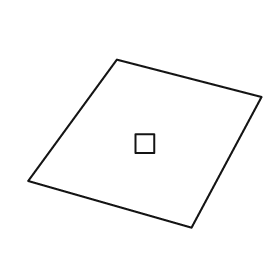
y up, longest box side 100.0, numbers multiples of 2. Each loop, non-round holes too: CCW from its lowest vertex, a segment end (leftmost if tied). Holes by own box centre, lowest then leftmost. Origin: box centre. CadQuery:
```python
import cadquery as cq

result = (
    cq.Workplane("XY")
    .moveTo(20.0, -36.0)
    .lineTo(50.0, 20.0)
    .lineTo(-12.0, 36.0)
    .lineTo(-50.0, -16.0)
    .close()
    .moveTo(-4.0, -4.0)
    .lineTo(4.0, -4.0)
    .lineTo(4.0, 4.0)
    .lineTo(-4.0, 4.0)
    .close()
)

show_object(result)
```